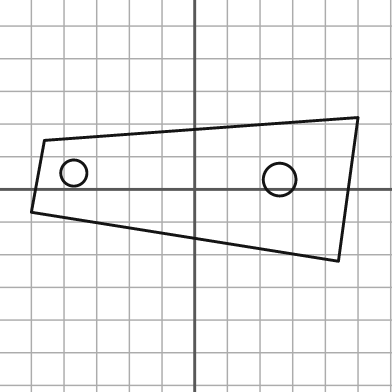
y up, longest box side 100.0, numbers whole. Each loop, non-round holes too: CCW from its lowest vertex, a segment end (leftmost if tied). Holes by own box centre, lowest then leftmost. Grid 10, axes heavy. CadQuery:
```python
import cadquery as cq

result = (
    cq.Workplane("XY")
    .moveTo(44.0, -22.0)
    .lineTo(50.0, 22.0)
    .lineTo(-46.0, 15.0)
    .lineTo(-50.0, -7.0)
    .close()
    .moveTo(26.0, 3.0)
    .circle(5.0)
    .moveTo(-37.0, 5.0)
    .circle(4.0)
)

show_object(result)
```